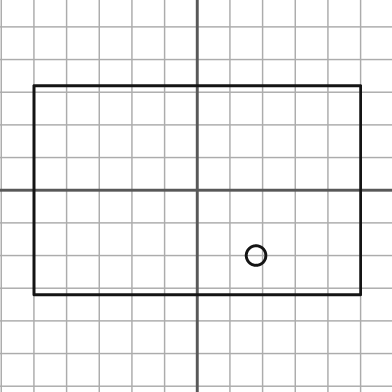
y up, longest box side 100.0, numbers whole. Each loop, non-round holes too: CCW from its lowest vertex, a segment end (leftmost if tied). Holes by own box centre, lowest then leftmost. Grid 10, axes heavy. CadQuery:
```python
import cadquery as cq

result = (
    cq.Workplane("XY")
    .moveTo(-50.0, -32.0)
    .lineTo(50.0, -32.0)
    .lineTo(50.0, 32.0)
    .lineTo(-50.0, 32.0)
    .close()
    .moveTo(18.0, -20.0)
    .circle(3.0)
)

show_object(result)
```